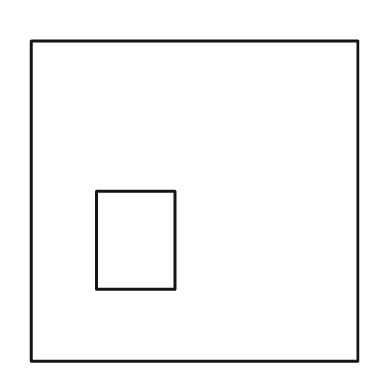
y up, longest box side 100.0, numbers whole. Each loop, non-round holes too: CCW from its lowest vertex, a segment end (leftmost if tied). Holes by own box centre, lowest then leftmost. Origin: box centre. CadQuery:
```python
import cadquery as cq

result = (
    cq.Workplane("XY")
    .moveTo(-50.0, -49.0)
    .lineTo(50.0, -49.0)
    .lineTo(50.0, 49.0)
    .lineTo(-50.0, 49.0)
    .close()
    .moveTo(-30.0, -27.0)
    .lineTo(-6.0, -27.0)
    .lineTo(-6.0, 3.0)
    .lineTo(-30.0, 3.0)
    .close()
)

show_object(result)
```